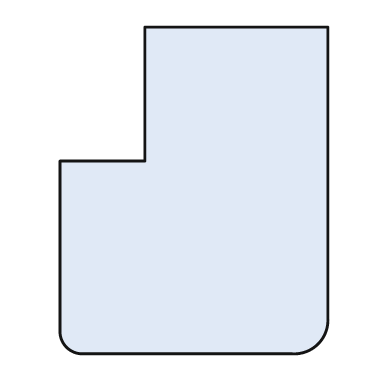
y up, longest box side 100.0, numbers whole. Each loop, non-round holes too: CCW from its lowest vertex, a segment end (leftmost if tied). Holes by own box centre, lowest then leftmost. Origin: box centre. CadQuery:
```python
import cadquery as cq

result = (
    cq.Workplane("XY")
    .moveTo(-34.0, -50.0)
    .lineTo(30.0, -50.0)
    .threePointArc((38.0, -47.0), (41.0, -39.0))
    .lineTo(41.0, 50.0)
    .lineTo(-15.0, 50.0)
    .lineTo(-15.0, 9.0)
    .lineTo(-41.0, 9.0)
    .lineTo(-41.0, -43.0)
    .threePointArc((-39.0, -48.0), (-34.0, -50.0))
    .close()
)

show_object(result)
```